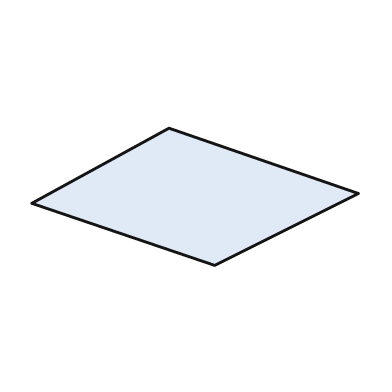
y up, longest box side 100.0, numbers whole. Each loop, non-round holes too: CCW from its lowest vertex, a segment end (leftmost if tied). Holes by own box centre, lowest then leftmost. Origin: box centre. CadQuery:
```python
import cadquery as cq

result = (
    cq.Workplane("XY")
    .moveTo(6.0, -21.0)
    .lineTo(50.0, 1.0)
    .lineTo(-8.0, 21.0)
    .lineTo(-50.0, -2.0)
    .close()
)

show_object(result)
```